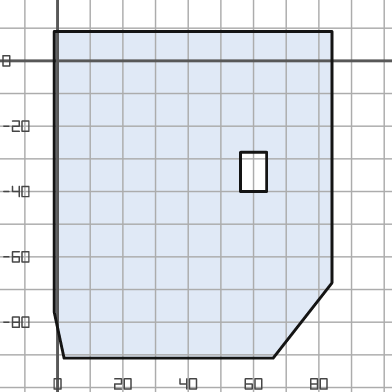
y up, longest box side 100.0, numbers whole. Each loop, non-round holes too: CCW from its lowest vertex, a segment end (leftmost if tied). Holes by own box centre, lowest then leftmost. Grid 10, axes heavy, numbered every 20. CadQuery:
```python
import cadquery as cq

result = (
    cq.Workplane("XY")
    .moveTo(2.0, -91.0)
    .lineTo(66.0, -91.0)
    .lineTo(84.0, -68.0)
    .lineTo(84.0, 9.0)
    .lineTo(-1.0, 9.0)
    .lineTo(-1.0, -77.0)
    .close()
    .moveTo(56.0, -40.0)
    .lineTo(64.0, -40.0)
    .lineTo(64.0, -28.0)
    .lineTo(56.0, -28.0)
    .close()
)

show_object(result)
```